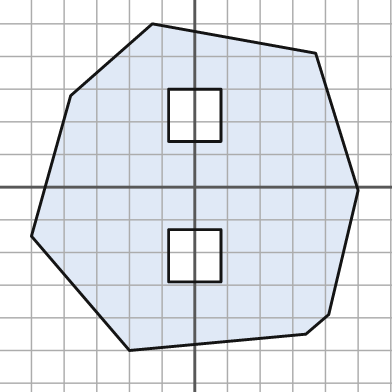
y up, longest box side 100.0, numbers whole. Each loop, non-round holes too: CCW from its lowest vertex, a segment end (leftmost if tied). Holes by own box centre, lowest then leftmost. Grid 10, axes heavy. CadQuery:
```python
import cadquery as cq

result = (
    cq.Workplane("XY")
    .moveTo(-20.0, -50.0)
    .lineTo(34.0, -45.0)
    .lineTo(41.0, -39.0)
    .lineTo(50.0, -1.0)
    .lineTo(37.0, 41.0)
    .lineTo(-13.0, 50.0)
    .lineTo(-38.0, 28.0)
    .lineTo(-50.0, -15.0)
    .close()
    .moveTo(-8.0, -29.0)
    .lineTo(8.0, -29.0)
    .lineTo(8.0, -13.0)
    .lineTo(-8.0, -13.0)
    .close()
    .moveTo(-8.0, 14.0)
    .lineTo(8.0, 14.0)
    .lineTo(8.0, 30.0)
    .lineTo(-8.0, 30.0)
    .close()
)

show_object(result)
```